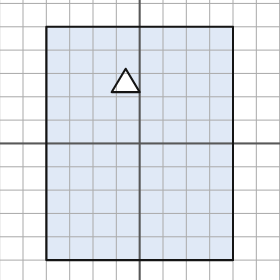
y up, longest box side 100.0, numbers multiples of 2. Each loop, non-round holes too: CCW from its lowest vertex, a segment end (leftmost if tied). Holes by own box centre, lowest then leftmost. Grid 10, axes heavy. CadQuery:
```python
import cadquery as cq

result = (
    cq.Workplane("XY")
    .moveTo(-40.0, -50.0)
    .lineTo(40.0, -50.0)
    .lineTo(40.0, 50.0)
    .lineTo(-40.0, 50.0)
    .close()
    .moveTo(-12.0, 22.0)
    .lineTo(0.0, 22.0)
    .lineTo(-6.0, 32.0)
    .close()
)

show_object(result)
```